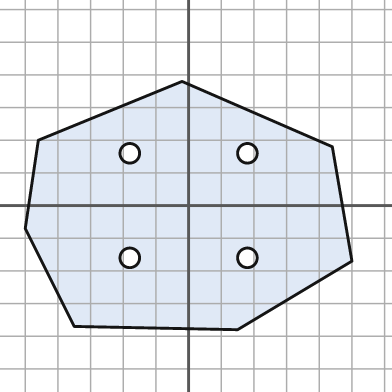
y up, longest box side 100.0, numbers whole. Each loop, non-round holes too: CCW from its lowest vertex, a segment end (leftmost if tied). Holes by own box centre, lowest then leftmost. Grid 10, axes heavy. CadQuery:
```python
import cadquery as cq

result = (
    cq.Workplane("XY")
    .moveTo(15.0, -38.0)
    .lineTo(50.0, -17.0)
    .lineTo(44.0, 18.0)
    .lineTo(-2.0, 38.0)
    .lineTo(-46.0, 20.0)
    .lineTo(-50.0, -7.0)
    .lineTo(-35.0, -37.0)
    .close()
    .moveTo(-18.0, -16.0)
    .circle(3.0)
    .moveTo(18.0, -16.0)
    .circle(3.0)
    .moveTo(-18.0, 16.0)
    .circle(3.0)
    .moveTo(18.0, 16.0)
    .circle(3.0)
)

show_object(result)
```